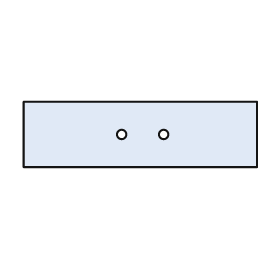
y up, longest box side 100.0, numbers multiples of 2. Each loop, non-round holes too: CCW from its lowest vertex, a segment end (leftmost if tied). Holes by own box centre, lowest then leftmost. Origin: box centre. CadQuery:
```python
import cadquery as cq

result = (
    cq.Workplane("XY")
    .moveTo(-50.0, -14.0)
    .lineTo(50.0, -14.0)
    .lineTo(50.0, 14.0)
    .lineTo(-50.0, 14.0)
    .close()
    .moveTo(-8.0, 0.0)
    .circle(2.0)
    .moveTo(10.0, 0.0)
    .circle(2.0)
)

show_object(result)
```